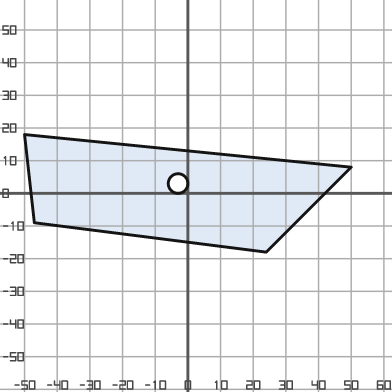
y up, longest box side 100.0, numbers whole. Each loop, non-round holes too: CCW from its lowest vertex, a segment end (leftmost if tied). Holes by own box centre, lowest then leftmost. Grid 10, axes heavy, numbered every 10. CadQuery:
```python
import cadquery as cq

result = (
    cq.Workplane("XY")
    .moveTo(24.0, -18.0)
    .lineTo(50.0, 8.0)
    .lineTo(-50.0, 18.0)
    .lineTo(-47.0, -9.0)
    .close()
    .moveTo(-3.0, 3.0)
    .circle(3.0)
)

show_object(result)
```